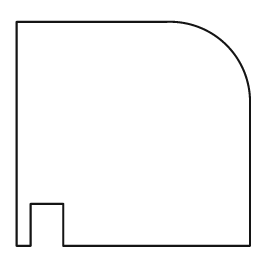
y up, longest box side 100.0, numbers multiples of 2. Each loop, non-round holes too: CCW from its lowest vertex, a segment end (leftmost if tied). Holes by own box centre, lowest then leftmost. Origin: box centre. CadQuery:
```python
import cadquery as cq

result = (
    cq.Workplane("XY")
    .moveTo(-50.0, -48.0)
    .lineTo(-44.0, -48.0)
    .lineTo(-44.0, -30.0)
    .lineTo(-30.0, -30.0)
    .lineTo(-30.0, -48.0)
    .lineTo(50.0, -48.0)
    .lineTo(50.0, 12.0)
    .threePointArc((40.0, 38.0), (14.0, 48.0))
    .lineTo(-50.0, 48.0)
    .close()
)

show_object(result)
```